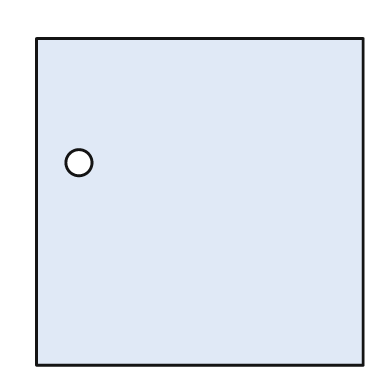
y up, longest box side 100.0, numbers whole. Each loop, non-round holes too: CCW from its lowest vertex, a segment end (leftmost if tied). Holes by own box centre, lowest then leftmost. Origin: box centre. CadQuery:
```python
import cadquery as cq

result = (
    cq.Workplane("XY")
    .moveTo(-50.0, -50.0)
    .lineTo(50.0, -50.0)
    .lineTo(50.0, 50.0)
    .lineTo(-50.0, 50.0)
    .close()
    .moveTo(-37.0, 12.0)
    .circle(4.0)
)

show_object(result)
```